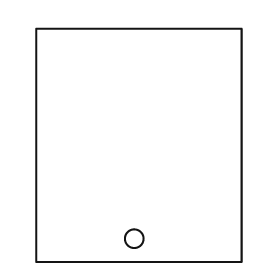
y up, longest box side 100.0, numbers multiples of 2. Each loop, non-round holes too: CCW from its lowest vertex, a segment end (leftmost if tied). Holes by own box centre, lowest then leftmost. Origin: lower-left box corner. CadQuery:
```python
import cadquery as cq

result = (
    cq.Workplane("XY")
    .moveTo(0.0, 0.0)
    .lineTo(88.0, 0.0)
    .lineTo(88.0, 100.0)
    .lineTo(0.0, 100.0)
    .close()
    .moveTo(42.0, 10.0)
    .circle(4.0)
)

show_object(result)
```